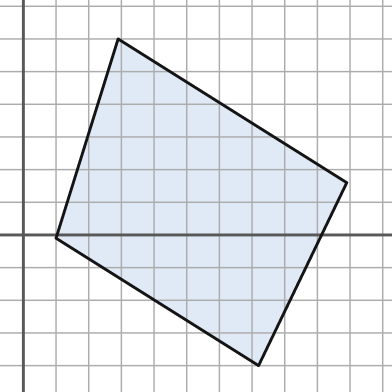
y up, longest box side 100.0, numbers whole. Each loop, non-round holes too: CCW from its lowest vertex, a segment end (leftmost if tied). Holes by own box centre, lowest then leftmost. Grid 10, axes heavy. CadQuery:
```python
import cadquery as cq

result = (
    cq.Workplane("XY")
    .moveTo(72.0, -40.0)
    .lineTo(99.0, 16.0)
    .lineTo(29.0, 60.0)
    .lineTo(10.0, -1.0)
    .close()
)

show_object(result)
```